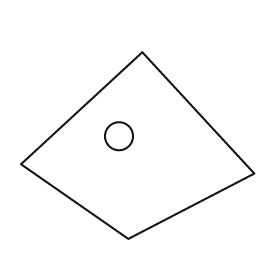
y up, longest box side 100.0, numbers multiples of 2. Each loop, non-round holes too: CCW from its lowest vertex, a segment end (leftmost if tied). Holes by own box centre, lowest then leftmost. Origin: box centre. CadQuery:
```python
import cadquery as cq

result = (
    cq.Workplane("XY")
    .moveTo(-4.0, -40.0)
    .lineTo(50.0, -12.0)
    .lineTo(2.0, 40.0)
    .lineTo(-50.0, -8.0)
    .close()
    .moveTo(-8.0, 4.0)
    .circle(6.0)
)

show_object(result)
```